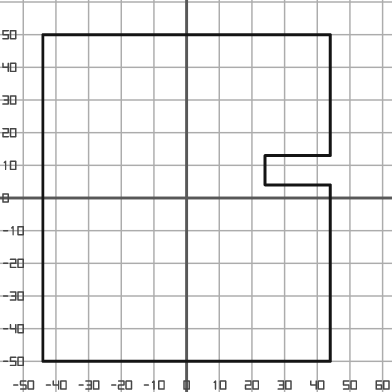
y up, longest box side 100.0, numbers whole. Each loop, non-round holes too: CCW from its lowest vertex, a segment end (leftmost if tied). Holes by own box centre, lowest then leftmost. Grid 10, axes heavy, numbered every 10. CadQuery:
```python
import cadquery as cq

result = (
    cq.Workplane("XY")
    .moveTo(-44.0, -50.0)
    .lineTo(44.0, -50.0)
    .lineTo(44.0, 4.0)
    .lineTo(24.0, 4.0)
    .lineTo(24.0, 13.0)
    .lineTo(44.0, 13.0)
    .lineTo(44.0, 50.0)
    .lineTo(-44.0, 50.0)
    .close()
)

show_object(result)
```